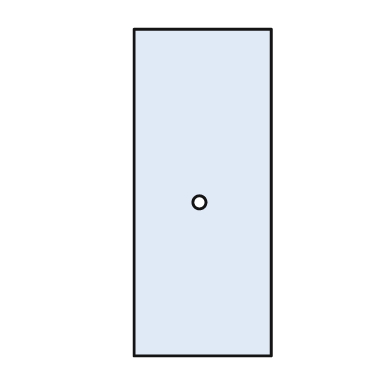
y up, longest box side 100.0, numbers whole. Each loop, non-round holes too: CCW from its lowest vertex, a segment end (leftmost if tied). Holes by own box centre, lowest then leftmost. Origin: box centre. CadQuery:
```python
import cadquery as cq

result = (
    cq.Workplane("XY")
    .moveTo(-21.0, -50.0)
    .lineTo(21.0, -50.0)
    .lineTo(21.0, 50.0)
    .lineTo(-21.0, 50.0)
    .close()
    .moveTo(-1.0, -3.0)
    .circle(2.0)
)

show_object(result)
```